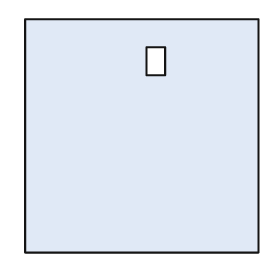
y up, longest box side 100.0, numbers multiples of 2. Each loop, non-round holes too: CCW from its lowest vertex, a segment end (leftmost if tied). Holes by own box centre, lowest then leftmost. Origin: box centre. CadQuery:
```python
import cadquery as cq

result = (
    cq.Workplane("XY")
    .moveTo(-50.0, -50.0)
    .lineTo(50.0, -50.0)
    .lineTo(50.0, 50.0)
    .lineTo(-50.0, 50.0)
    .close()
    .moveTo(2.0, 26.0)
    .lineTo(10.0, 26.0)
    .lineTo(10.0, 38.0)
    .lineTo(2.0, 38.0)
    .close()
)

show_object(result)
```